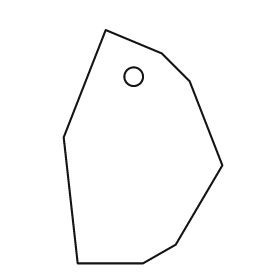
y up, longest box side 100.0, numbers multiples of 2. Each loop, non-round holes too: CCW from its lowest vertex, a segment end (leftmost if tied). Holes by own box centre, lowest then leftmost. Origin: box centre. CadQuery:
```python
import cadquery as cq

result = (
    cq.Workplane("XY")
    .moveTo(-28.0, -50.0)
    .lineTo(0.0, -50.0)
    .lineTo(14.0, -42.0)
    .lineTo(34.0, -8.0)
    .lineTo(20.0, 28.0)
    .lineTo(8.0, 40.0)
    .lineTo(-16.0, 50.0)
    .lineTo(-34.0, 4.0)
    .close()
    .moveTo(-4.0, 30.0)
    .circle(4.0)
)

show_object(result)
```